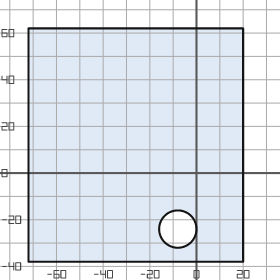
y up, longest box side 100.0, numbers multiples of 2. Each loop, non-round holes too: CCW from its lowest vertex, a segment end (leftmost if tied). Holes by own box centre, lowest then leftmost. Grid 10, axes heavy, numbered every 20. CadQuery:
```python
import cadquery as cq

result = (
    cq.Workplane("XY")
    .moveTo(-72.0, -38.0)
    .lineTo(20.0, -38.0)
    .lineTo(20.0, 62.0)
    .lineTo(-72.0, 62.0)
    .close()
    .moveTo(-8.0, -24.0)
    .circle(8.0)
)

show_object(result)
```